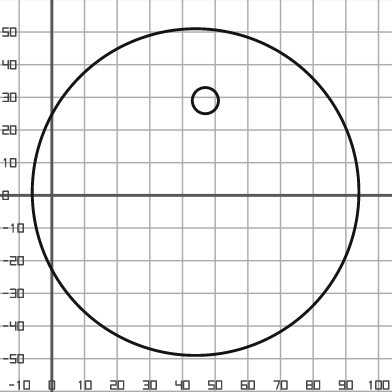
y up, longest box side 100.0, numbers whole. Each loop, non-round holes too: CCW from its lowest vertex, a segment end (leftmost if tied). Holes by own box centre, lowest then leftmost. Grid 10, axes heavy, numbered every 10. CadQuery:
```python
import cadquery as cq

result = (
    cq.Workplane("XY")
    .moveTo(44.0, 1.0)
    .circle(50.0)
    .moveTo(47.0, 29.0)
    .circle(4.0)
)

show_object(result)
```